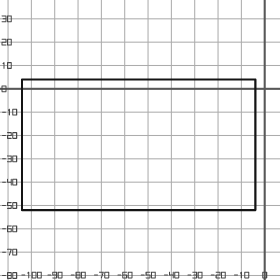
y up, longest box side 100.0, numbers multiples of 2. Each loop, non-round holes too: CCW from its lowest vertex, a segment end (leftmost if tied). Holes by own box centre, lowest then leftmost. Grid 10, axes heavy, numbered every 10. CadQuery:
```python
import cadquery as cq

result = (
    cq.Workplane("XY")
    .moveTo(-104.0, -52.0)
    .lineTo(-4.0, -52.0)
    .lineTo(-4.0, 4.0)
    .lineTo(-104.0, 4.0)
    .close()
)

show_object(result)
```